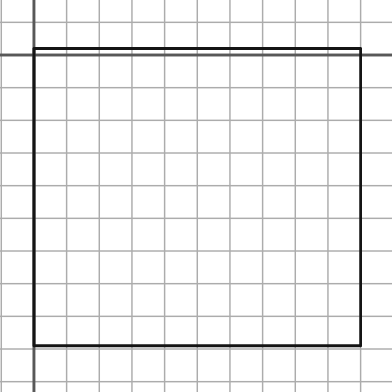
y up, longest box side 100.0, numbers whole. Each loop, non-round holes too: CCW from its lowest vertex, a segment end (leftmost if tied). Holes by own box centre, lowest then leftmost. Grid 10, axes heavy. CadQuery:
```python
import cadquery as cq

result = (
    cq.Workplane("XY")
    .moveTo(0.0, -89.0)
    .lineTo(100.0, -89.0)
    .lineTo(100.0, 2.0)
    .lineTo(0.0, 2.0)
    .close()
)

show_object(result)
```